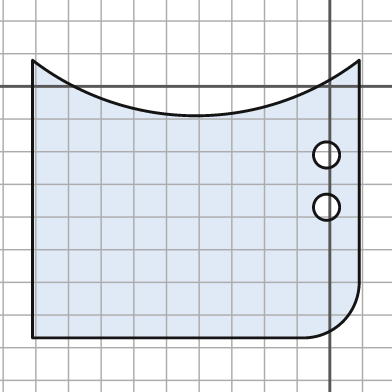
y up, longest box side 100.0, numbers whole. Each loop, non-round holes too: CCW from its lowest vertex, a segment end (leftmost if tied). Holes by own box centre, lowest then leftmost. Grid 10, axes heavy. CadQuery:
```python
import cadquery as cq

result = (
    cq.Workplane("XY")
    .moveTo(-91.0, -77.0)
    .lineTo(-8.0, -77.0)
    .threePointArc((4.0, -72.0), (9.0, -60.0))
    .lineTo(9.0, 8.0)
    .threePointArc((-41.0, -9.0), (-91.0, 8.0))
    .close()
    .moveTo(-1.0, -37.0)
    .circle(4.0)
    .moveTo(-1.0, -21.0)
    .circle(4.0)
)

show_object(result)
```